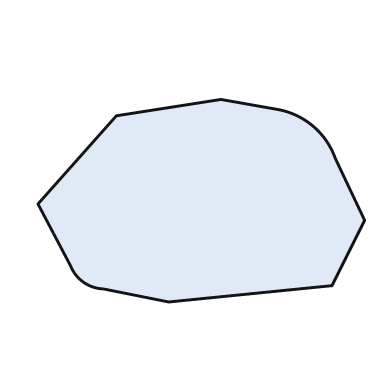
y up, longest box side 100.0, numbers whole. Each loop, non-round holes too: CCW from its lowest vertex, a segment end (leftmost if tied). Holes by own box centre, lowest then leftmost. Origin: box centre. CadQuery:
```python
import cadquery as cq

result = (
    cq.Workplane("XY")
    .moveTo(-10.0, -31.0)
    .lineTo(40.0, -26.0)
    .lineTo(50.0, -6.0)
    .lineTo(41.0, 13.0)
    .threePointArc((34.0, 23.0), (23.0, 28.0))
    .lineTo(6.0, 31.0)
    .lineTo(-26.0, 26.0)
    .lineTo(-50.0, -1.0)
    .lineTo(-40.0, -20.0)
    .threePointArc((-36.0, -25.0), (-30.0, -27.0))
    .close()
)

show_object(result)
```